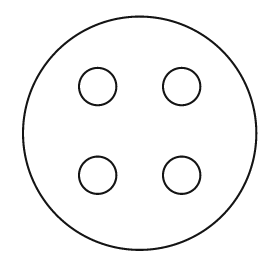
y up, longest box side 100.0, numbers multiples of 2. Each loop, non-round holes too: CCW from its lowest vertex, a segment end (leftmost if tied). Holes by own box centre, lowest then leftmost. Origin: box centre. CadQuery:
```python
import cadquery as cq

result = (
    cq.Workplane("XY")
    .moveTo(0.0, 0.0)
    .circle(50.0)
    .moveTo(-18.0, -18.0)
    .circle(8.0)
    .moveTo(18.0, -18.0)
    .circle(8.0)
    .moveTo(-18.0, 20.0)
    .circle(8.0)
    .moveTo(18.0, 20.0)
    .circle(8.0)
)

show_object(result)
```